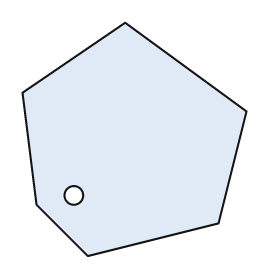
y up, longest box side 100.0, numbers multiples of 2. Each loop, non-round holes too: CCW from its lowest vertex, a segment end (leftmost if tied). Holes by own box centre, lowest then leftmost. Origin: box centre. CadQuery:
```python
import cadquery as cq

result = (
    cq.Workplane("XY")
    .moveTo(-20.0, -50.0)
    .lineTo(36.0, -36.0)
    .lineTo(48.0, 12.0)
    .lineTo(-4.0, 50.0)
    .lineTo(-48.0, 20.0)
    .lineTo(-42.0, -28.0)
    .close()
    .moveTo(-26.0, -24.0)
    .circle(4.0)
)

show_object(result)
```